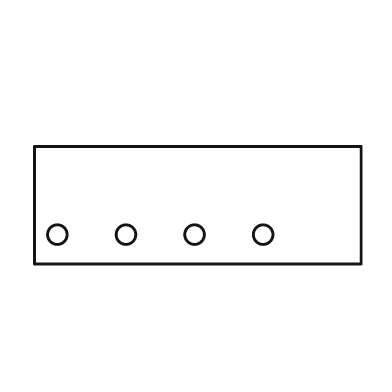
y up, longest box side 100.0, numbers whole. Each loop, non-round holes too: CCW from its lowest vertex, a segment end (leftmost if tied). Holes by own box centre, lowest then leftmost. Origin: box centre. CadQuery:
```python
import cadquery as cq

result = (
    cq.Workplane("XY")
    .moveTo(-50.0, -18.0)
    .lineTo(50.0, -18.0)
    .lineTo(50.0, 18.0)
    .lineTo(-50.0, 18.0)
    .close()
    .moveTo(-43.0, -9.0)
    .circle(3.0)
    .moveTo(-22.0, -9.0)
    .circle(3.0)
    .moveTo(-1.0, -9.0)
    .circle(3.0)
    .moveTo(20.0, -9.0)
    .circle(3.0)
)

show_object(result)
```